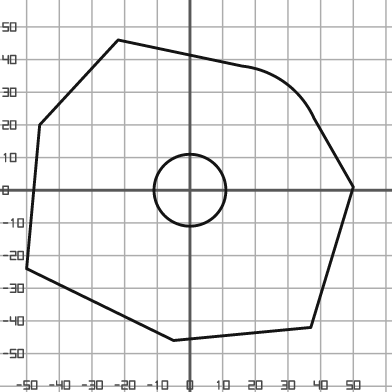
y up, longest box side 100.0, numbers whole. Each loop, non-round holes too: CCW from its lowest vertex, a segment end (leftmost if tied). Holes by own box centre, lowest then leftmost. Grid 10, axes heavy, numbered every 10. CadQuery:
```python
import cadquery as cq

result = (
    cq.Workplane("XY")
    .moveTo(-5.0, -46.0)
    .lineTo(37.0, -42.0)
    .lineTo(50.0, 1.0)
    .lineTo(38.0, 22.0)
    .threePointArc((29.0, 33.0), (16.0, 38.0))
    .lineTo(-22.0, 46.0)
    .lineTo(-46.0, 20.0)
    .lineTo(-50.0, -24.0)
    .close()
    .moveTo(0.0, 0.0)
    .circle(11.0)
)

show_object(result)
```